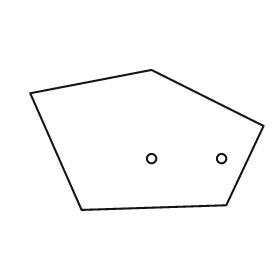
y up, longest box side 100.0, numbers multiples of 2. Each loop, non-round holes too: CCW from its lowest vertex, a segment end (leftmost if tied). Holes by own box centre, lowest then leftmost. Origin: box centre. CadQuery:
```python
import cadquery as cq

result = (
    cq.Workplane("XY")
    .moveTo(-28.0, -30.0)
    .lineTo(34.0, -28.0)
    .lineTo(50.0, 6.0)
    .lineTo(2.0, 30.0)
    .lineTo(-50.0, 20.0)
    .close()
    .moveTo(2.0, -8.0)
    .circle(2.0)
    .moveTo(32.0, -8.0)
    .circle(2.0)
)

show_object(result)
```